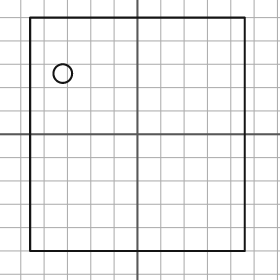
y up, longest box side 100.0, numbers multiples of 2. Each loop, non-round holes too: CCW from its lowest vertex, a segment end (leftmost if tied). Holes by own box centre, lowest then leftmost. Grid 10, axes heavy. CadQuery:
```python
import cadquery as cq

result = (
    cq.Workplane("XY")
    .moveTo(-46.0, -50.0)
    .lineTo(46.0, -50.0)
    .lineTo(46.0, 50.0)
    .lineTo(-46.0, 50.0)
    .close()
    .moveTo(-32.0, 26.0)
    .circle(4.0)
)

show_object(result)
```